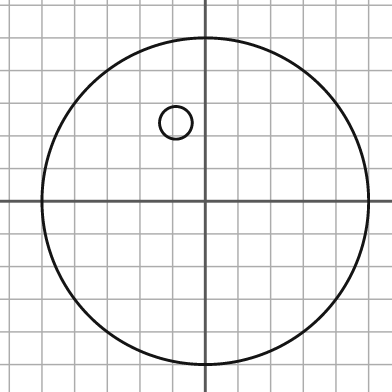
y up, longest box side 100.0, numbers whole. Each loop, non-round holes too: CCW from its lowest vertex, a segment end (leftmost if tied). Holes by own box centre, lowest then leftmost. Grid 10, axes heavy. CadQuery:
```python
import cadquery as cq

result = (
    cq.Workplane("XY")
    .moveTo(0.0, 0.0)
    .circle(50.0)
    .moveTo(-9.0, 24.0)
    .circle(5.0)
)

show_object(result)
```